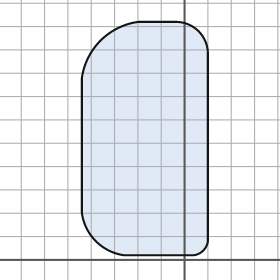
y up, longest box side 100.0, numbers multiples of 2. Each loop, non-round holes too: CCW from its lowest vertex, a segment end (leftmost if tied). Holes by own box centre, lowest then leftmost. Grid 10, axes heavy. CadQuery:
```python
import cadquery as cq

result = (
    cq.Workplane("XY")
    .moveTo(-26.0, 2.0)
    .lineTo(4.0, 2.0)
    .threePointArc((8.0, 4.0), (10.0, 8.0))
    .lineTo(10.0, 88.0)
    .threePointArc((6.0, 98.0), (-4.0, 102.0))
    .lineTo(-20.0, 102.0)
    .threePointArc((-36.0, 94.0), (-44.0, 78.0))
    .lineTo(-44.0, 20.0)
    .threePointArc((-38.0, 8.0), (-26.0, 2.0))
    .close()
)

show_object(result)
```